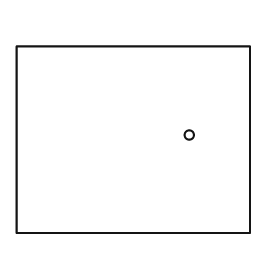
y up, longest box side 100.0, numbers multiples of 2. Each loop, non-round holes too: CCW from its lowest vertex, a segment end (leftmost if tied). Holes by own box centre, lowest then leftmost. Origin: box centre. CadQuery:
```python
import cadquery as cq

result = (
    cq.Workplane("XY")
    .moveTo(-50.0, -40.0)
    .lineTo(50.0, -40.0)
    .lineTo(50.0, 40.0)
    .lineTo(-50.0, 40.0)
    .close()
    .moveTo(24.0, 2.0)
    .circle(2.0)
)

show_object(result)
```